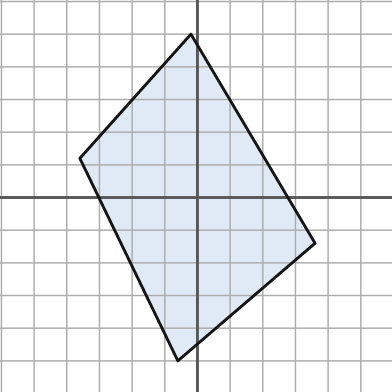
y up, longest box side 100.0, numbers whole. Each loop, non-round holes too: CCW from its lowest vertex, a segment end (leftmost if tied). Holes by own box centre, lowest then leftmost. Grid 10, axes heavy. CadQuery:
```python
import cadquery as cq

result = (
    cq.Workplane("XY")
    .moveTo(-6.0, -50.0)
    .lineTo(36.0, -14.0)
    .lineTo(-2.0, 50.0)
    .lineTo(-36.0, 12.0)
    .close()
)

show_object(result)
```